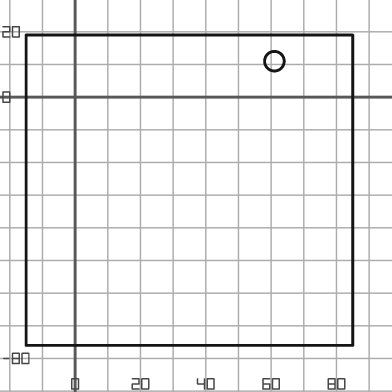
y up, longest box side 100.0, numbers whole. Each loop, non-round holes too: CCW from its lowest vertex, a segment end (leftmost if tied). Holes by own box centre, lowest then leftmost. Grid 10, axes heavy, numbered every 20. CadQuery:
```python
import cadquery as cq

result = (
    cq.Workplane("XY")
    .moveTo(-15.0, -76.0)
    .lineTo(85.0, -76.0)
    .lineTo(85.0, 19.0)
    .lineTo(-15.0, 19.0)
    .close()
    .moveTo(61.0, 11.0)
    .circle(3.0)
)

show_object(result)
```